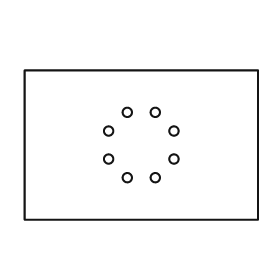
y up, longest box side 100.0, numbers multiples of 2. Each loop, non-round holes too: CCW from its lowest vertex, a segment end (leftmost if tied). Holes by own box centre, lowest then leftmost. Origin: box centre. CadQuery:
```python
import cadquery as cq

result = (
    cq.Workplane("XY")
    .moveTo(-50.0, -32.0)
    .lineTo(50.0, -32.0)
    .lineTo(50.0, 32.0)
    .lineTo(-50.0, 32.0)
    .close()
    .moveTo(-6.0, -14.0)
    .circle(2.0)
    .moveTo(6.0, -14.0)
    .circle(2.0)
    .moveTo(-14.0, -6.0)
    .circle(2.0)
    .moveTo(14.0, -6.0)
    .circle(2.0)
    .moveTo(-14.0, 6.0)
    .circle(2.0)
    .moveTo(14.0, 6.0)
    .circle(2.0)
    .moveTo(-6.0, 14.0)
    .circle(2.0)
    .moveTo(6.0, 14.0)
    .circle(2.0)
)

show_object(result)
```